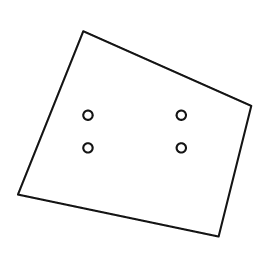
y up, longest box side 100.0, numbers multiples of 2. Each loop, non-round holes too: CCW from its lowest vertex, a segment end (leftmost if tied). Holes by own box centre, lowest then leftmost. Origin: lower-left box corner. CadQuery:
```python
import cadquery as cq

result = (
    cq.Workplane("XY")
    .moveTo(86.0, 0.0)
    .lineTo(100.0, 56.0)
    .lineTo(28.0, 88.0)
    .lineTo(0.0, 18.0)
    .close()
    .moveTo(30.0, 38.0)
    .circle(2.0)
    .moveTo(70.0, 38.0)
    .circle(2.0)
    .moveTo(30.0, 52.0)
    .circle(2.0)
    .moveTo(70.0, 52.0)
    .circle(2.0)
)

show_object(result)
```